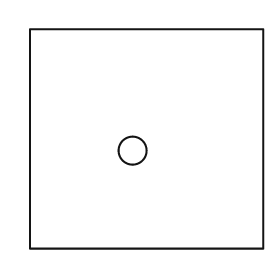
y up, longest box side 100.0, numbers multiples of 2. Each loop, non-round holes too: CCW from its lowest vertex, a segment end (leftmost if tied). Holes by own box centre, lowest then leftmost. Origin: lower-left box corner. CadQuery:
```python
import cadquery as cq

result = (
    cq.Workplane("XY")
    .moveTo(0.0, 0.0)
    .lineTo(100.0, 0.0)
    .lineTo(100.0, 94.0)
    .lineTo(0.0, 94.0)
    .close()
    .moveTo(44.0, 42.0)
    .circle(6.0)
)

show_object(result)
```